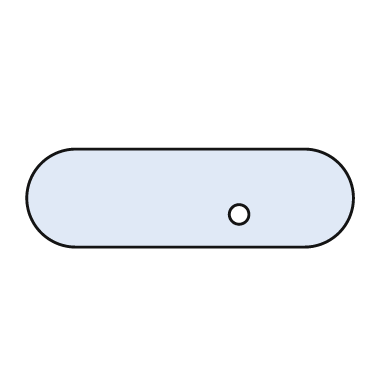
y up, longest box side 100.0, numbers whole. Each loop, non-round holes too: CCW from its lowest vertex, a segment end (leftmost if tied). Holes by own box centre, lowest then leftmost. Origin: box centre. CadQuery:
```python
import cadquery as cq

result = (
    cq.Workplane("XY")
    .moveTo(-35.0, -15.0)
    .lineTo(35.0, -15.0)
    .threePointArc((50.0, 0.0), (35.0, 15.0))
    .lineTo(-35.0, 15.0)
    .threePointArc((-50.0, 0.0), (-35.0, -15.0))
    .close()
    .moveTo(15.0, -5.0)
    .circle(3.0)
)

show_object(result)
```